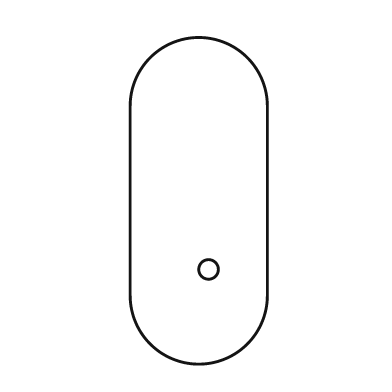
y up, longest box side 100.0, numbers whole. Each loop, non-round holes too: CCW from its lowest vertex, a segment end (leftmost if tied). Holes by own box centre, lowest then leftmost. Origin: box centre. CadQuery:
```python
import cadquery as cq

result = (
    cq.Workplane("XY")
    .moveTo(-21.0, -29.0)
    .threePointArc((0.0, -50.0), (21.0, -29.0))
    .lineTo(21.0, 29.0)
    .threePointArc((0.0, 50.0), (-21.0, 29.0))
    .close()
    .moveTo(3.0, -21.0)
    .circle(3.0)
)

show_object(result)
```